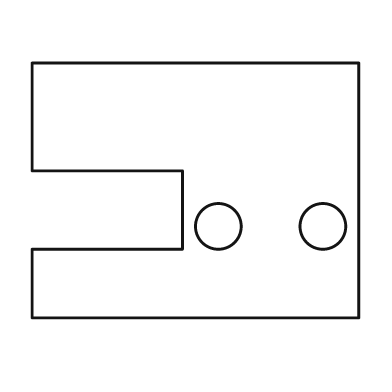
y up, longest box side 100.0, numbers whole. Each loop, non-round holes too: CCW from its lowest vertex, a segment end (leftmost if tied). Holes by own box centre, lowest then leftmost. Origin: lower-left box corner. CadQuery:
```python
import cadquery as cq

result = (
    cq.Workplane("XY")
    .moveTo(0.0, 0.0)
    .lineTo(100.0, 0.0)
    .lineTo(100.0, 78.0)
    .lineTo(0.0, 78.0)
    .lineTo(0.0, 45.0)
    .lineTo(46.0, 45.0)
    .lineTo(46.0, 21.0)
    .lineTo(0.0, 21.0)
    .close()
    .moveTo(57.0, 28.0)
    .circle(7.0)
    .moveTo(89.0, 28.0)
    .circle(7.0)
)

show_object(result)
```